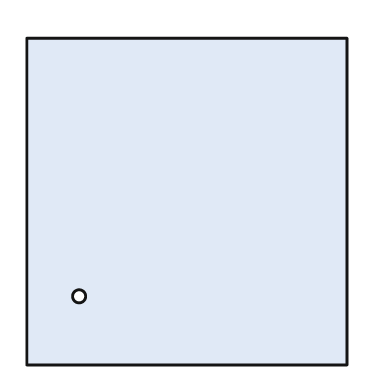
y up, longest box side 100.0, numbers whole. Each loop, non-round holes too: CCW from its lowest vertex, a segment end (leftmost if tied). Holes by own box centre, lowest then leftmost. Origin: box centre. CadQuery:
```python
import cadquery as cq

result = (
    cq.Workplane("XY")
    .moveTo(-49.0, -50.0)
    .lineTo(49.0, -50.0)
    .lineTo(49.0, 50.0)
    .lineTo(-49.0, 50.0)
    .close()
    .moveTo(-33.0, -29.0)
    .circle(2.0)
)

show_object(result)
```